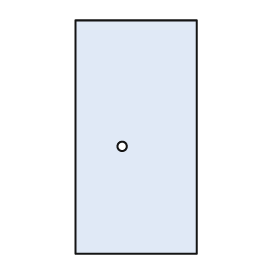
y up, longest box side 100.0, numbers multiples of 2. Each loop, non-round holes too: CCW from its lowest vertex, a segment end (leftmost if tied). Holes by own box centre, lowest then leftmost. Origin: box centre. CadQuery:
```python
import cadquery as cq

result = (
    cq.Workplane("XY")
    .moveTo(-26.0, -50.0)
    .lineTo(26.0, -50.0)
    .lineTo(26.0, 50.0)
    .lineTo(-26.0, 50.0)
    .close()
    .moveTo(-6.0, -4.0)
    .circle(2.0)
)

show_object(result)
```